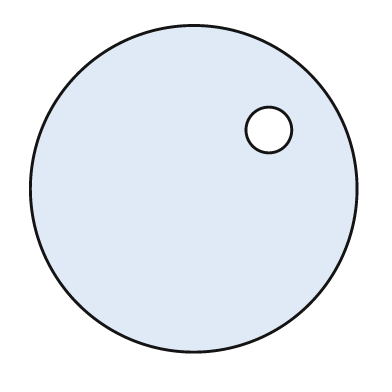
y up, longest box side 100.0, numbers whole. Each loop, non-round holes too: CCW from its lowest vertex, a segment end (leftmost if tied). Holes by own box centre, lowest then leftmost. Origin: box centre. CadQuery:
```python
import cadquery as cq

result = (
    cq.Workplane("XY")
    .moveTo(0.0, 0.0)
    .circle(50.0)
    .moveTo(23.0, 18.0)
    .circle(7.0)
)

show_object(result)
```